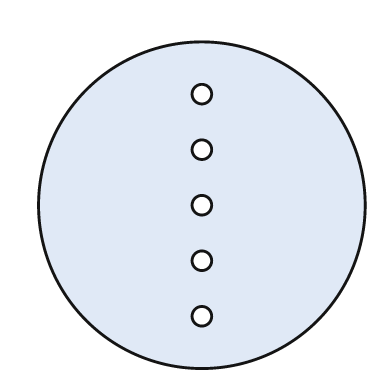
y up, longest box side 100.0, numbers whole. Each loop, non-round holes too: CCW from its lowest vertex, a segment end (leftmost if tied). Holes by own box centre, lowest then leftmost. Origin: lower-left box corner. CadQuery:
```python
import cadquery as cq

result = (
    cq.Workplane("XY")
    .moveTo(50.0, 50.0)
    .circle(50.0)
    .moveTo(50.0, 16.0)
    .circle(3.0)
    .moveTo(50.0, 33.0)
    .circle(3.0)
    .moveTo(50.0, 50.0)
    .circle(3.0)
    .moveTo(50.0, 67.0)
    .circle(3.0)
    .moveTo(50.0, 84.0)
    .circle(3.0)
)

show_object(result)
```